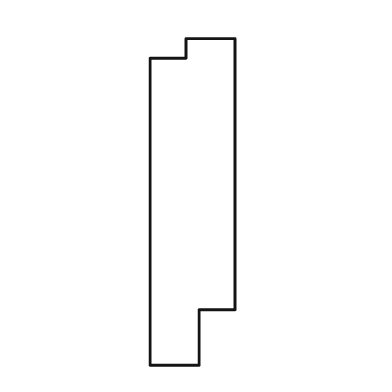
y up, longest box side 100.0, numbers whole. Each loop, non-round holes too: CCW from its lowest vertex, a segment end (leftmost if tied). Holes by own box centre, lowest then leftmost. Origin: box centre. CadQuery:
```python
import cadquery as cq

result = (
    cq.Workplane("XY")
    .moveTo(-13.0, -50.0)
    .lineTo(2.0, -50.0)
    .lineTo(2.0, -33.0)
    .lineTo(13.0, -33.0)
    .lineTo(13.0, 50.0)
    .lineTo(-2.0, 50.0)
    .lineTo(-2.0, 44.0)
    .lineTo(-13.0, 44.0)
    .close()
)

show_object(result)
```